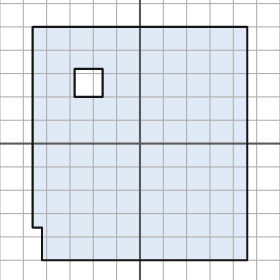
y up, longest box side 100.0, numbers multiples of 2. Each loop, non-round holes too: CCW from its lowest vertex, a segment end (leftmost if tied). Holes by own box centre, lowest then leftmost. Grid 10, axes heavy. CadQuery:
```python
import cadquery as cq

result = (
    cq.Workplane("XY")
    .moveTo(-42.0, -50.0)
    .lineTo(46.0, -50.0)
    .lineTo(46.0, 50.0)
    .lineTo(-46.0, 50.0)
    .lineTo(-46.0, -36.0)
    .lineTo(-42.0, -36.0)
    .close()
    .moveTo(-28.0, 20.0)
    .lineTo(-16.0, 20.0)
    .lineTo(-16.0, 32.0)
    .lineTo(-28.0, 32.0)
    .close()
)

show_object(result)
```